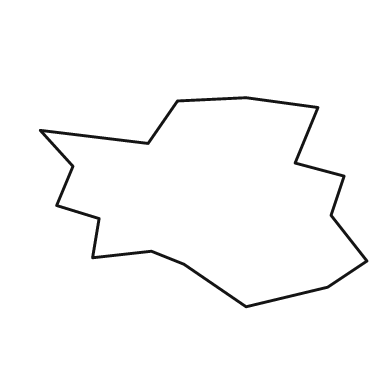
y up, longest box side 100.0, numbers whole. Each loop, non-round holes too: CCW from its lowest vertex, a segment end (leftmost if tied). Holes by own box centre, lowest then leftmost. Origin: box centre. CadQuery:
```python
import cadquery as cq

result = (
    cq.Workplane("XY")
    .moveTo(13.0, -32.0)
    .lineTo(38.0, -26.0)
    .lineTo(50.0, -18.0)
    .lineTo(39.0, -4.0)
    .lineTo(43.0, 8.0)
    .lineTo(28.0, 12.0)
    .lineTo(35.0, 29.0)
    .lineTo(13.0, 32.0)
    .lineTo(-8.0, 31.0)
    .lineTo(-17.0, 18.0)
    .lineTo(-50.0, 22.0)
    .lineTo(-40.0, 11.0)
    .lineTo(-45.0, -1.0)
    .lineTo(-32.0, -5.0)
    .lineTo(-34.0, -17.0)
    .lineTo(-16.0, -15.0)
    .lineTo(-6.0, -19.0)
    .close()
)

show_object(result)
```